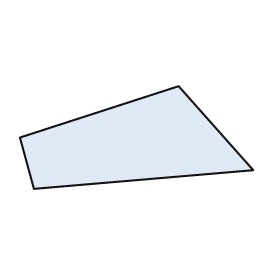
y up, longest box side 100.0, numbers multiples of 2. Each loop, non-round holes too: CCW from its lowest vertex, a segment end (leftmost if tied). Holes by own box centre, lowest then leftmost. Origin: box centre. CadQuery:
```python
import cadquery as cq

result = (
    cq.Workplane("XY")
    .moveTo(-44.0, -22.0)
    .lineTo(50.0, -14.0)
    .lineTo(18.0, 22.0)
    .lineTo(-50.0, 0.0)
    .close()
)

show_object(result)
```